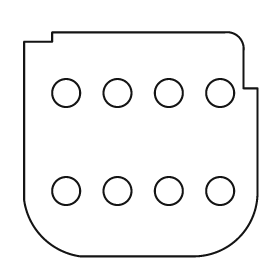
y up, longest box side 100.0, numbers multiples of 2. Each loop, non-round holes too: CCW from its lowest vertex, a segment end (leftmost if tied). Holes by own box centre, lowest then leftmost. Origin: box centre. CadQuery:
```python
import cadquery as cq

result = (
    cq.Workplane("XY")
    .moveTo(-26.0, -48.0)
    .lineTo(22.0, -48.0)
    .threePointArc((42.0, -40.0), (50.0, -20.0))
    .lineTo(50.0, 24.0)
    .lineTo(44.0, 24.0)
    .lineTo(44.0, 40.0)
    .threePointArc((42.0, 46.0), (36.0, 48.0))
    .lineTo(-38.0, 48.0)
    .lineTo(-38.0, 44.0)
    .lineTo(-50.0, 44.0)
    .lineTo(-50.0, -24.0)
    .threePointArc((-42.0, -40.0), (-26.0, -48.0))
    .close()
    .moveTo(-32.0, -20.0)
    .circle(6.0)
    .moveTo(-10.0, -20.0)
    .circle(6.0)
    .moveTo(12.0, -20.0)
    .circle(6.0)
    .moveTo(34.0, -20.0)
    .circle(6.0)
    .moveTo(-32.0, 22.0)
    .circle(6.0)
    .moveTo(-10.0, 22.0)
    .circle(6.0)
    .moveTo(12.0, 22.0)
    .circle(6.0)
    .moveTo(34.0, 22.0)
    .circle(6.0)
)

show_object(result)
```